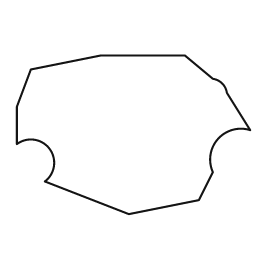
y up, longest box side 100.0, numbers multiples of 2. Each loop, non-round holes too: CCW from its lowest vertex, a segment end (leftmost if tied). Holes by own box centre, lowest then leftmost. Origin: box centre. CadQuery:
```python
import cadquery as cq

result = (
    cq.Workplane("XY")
    .moveTo(-2.0, -34.0)
    .lineTo(28.0, -28.0)
    .lineTo(34.0, -16.0)
    .threePointArc((36.0, -2.0), (50.0, 2.0))
    .lineTo(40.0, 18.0)
    .threePointArc((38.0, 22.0), (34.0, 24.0))
    .lineTo(22.0, 34.0)
    .lineTo(-14.0, 34.0)
    .lineTo(-44.0, 28.0)
    .lineTo(-50.0, 12.0)
    .lineTo(-50.0, -4.0)
    .threePointArc((-36.0, -6.0), (-38.0, -20.0))
    .close()
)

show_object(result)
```